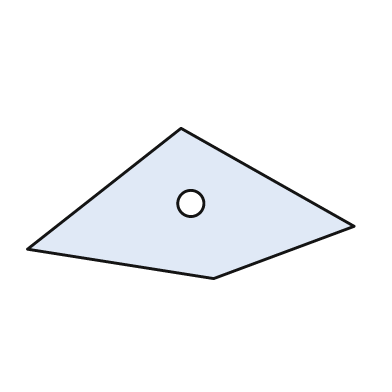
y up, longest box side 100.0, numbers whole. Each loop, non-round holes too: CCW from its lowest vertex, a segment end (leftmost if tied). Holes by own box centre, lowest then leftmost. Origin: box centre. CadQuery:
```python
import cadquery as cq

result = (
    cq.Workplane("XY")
    .moveTo(7.0, -23.0)
    .lineTo(50.0, -7.0)
    .lineTo(-3.0, 23.0)
    .lineTo(-50.0, -14.0)
    .close()
    .moveTo(0.0, 0.0)
    .circle(4.0)
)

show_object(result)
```